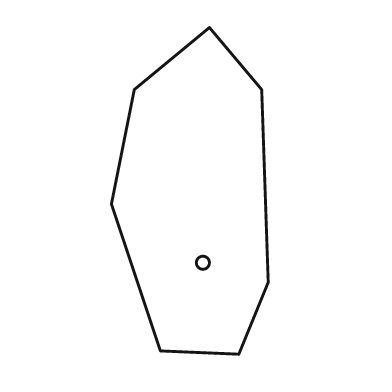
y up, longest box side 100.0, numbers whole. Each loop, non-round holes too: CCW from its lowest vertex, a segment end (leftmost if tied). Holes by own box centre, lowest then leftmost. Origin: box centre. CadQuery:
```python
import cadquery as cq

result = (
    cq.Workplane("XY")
    .moveTo(15.0, -50.0)
    .lineTo(24.0, -28.0)
    .lineTo(22.0, 31.0)
    .lineTo(6.0, 50.0)
    .lineTo(-17.0, 31.0)
    .lineTo(-24.0, -4.0)
    .lineTo(-9.0, -49.0)
    .close()
    .moveTo(4.0, -22.0)
    .circle(2.0)
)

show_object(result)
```